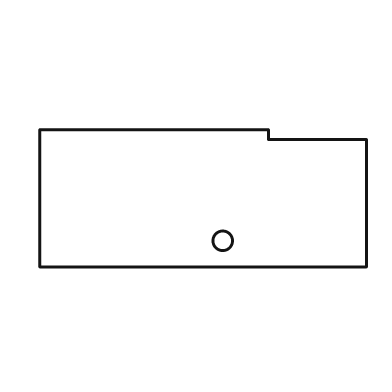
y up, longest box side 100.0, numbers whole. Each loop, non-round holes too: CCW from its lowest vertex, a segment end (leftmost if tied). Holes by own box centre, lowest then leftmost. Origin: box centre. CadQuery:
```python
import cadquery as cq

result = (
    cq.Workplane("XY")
    .moveTo(-50.0, -21.0)
    .lineTo(50.0, -21.0)
    .lineTo(50.0, 18.0)
    .lineTo(20.0, 18.0)
    .lineTo(20.0, 21.0)
    .lineTo(-50.0, 21.0)
    .close()
    .moveTo(6.0, -13.0)
    .circle(3.0)
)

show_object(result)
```